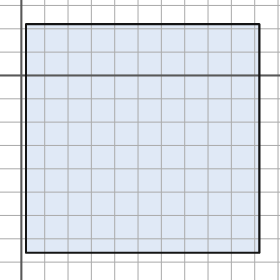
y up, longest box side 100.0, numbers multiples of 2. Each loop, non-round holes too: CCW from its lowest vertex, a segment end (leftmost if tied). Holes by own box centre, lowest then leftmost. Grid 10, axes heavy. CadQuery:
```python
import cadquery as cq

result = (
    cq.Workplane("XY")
    .moveTo(2.0, -76.0)
    .lineTo(102.0, -76.0)
    .lineTo(102.0, 22.0)
    .lineTo(2.0, 22.0)
    .close()
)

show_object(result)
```